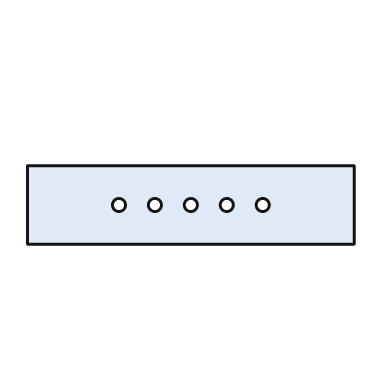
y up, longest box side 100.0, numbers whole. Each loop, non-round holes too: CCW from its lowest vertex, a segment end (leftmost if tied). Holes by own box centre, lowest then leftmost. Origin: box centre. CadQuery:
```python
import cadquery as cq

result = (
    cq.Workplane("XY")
    .moveTo(-50.0, -12.0)
    .lineTo(50.0, -12.0)
    .lineTo(50.0, 12.0)
    .lineTo(-50.0, 12.0)
    .close()
    .moveTo(-22.0, 0.0)
    .circle(2.0)
    .moveTo(-11.0, 0.0)
    .circle(2.0)
    .moveTo(0.0, 0.0)
    .circle(2.0)
    .moveTo(11.0, 0.0)
    .circle(2.0)
    .moveTo(22.0, 0.0)
    .circle(2.0)
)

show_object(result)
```